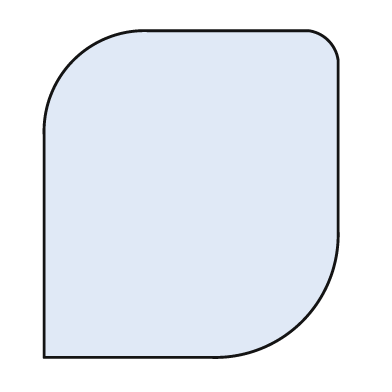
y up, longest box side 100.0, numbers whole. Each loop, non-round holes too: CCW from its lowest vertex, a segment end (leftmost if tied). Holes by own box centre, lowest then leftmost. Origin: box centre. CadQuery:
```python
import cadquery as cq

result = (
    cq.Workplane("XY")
    .moveTo(-45.0, -50.0)
    .lineTo(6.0, -50.0)
    .threePointArc((34.0, -39.0), (45.0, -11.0))
    .lineTo(45.0, 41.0)
    .threePointArc((42.0, 47.0), (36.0, 50.0))
    .lineTo(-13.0, 50.0)
    .threePointArc((-36.0, 41.0), (-45.0, 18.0))
    .close()
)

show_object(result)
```